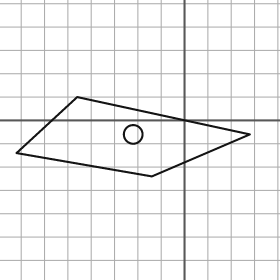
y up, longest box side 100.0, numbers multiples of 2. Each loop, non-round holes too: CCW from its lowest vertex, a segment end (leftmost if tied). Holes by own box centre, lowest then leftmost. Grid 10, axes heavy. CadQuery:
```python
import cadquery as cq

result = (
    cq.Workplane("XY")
    .moveTo(-14.0, -24.0)
    .lineTo(28.0, -6.0)
    .lineTo(-46.0, 10.0)
    .lineTo(-72.0, -14.0)
    .close()
    .moveTo(-22.0, -6.0)
    .circle(4.0)
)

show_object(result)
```